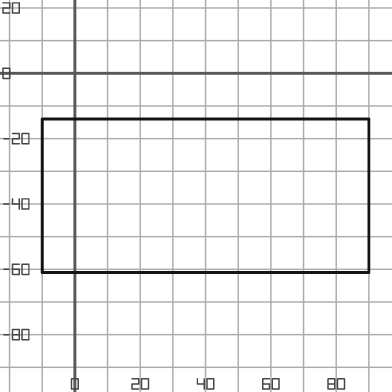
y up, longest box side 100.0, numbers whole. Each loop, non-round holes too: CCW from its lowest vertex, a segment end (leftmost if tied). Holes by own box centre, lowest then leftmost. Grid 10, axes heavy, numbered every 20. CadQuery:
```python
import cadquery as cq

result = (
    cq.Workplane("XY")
    .moveTo(-10.0, -61.0)
    .lineTo(90.0, -61.0)
    .lineTo(90.0, -14.0)
    .lineTo(-10.0, -14.0)
    .close()
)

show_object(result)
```